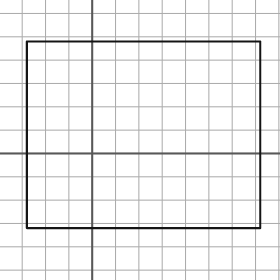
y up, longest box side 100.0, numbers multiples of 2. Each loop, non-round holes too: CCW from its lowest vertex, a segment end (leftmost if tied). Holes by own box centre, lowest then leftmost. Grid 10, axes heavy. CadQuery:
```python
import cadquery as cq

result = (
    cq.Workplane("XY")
    .moveTo(-28.0, -32.0)
    .lineTo(72.0, -32.0)
    .lineTo(72.0, 48.0)
    .lineTo(-28.0, 48.0)
    .close()
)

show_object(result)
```